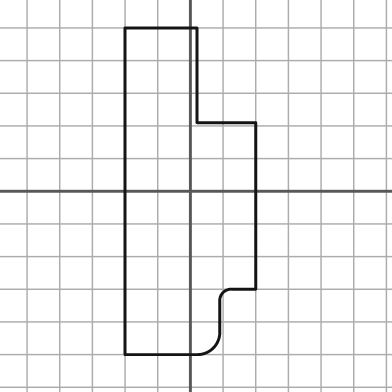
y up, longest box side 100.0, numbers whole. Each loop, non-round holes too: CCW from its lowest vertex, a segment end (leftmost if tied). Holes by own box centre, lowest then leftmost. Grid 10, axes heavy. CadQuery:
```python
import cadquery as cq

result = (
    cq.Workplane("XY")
    .moveTo(-20.0, -50.0)
    .lineTo(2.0, -50.0)
    .threePointArc((7.0, -48.0), (9.0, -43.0))
    .lineTo(9.0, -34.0)
    .threePointArc((10.0, -31.0), (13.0, -30.0))
    .lineTo(20.0, -30.0)
    .lineTo(20.0, 21.0)
    .lineTo(2.0, 21.0)
    .lineTo(2.0, 50.0)
    .lineTo(-20.0, 50.0)
    .close()
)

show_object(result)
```